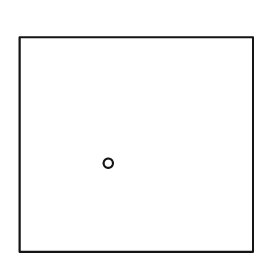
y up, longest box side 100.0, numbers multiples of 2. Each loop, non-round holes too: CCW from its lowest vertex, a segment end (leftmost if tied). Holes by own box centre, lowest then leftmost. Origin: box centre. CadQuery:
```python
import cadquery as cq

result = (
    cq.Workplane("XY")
    .moveTo(-50.0, -46.0)
    .lineTo(50.0, -46.0)
    .lineTo(50.0, 46.0)
    .lineTo(-50.0, 46.0)
    .close()
    .moveTo(-12.0, -8.0)
    .circle(2.0)
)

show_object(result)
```